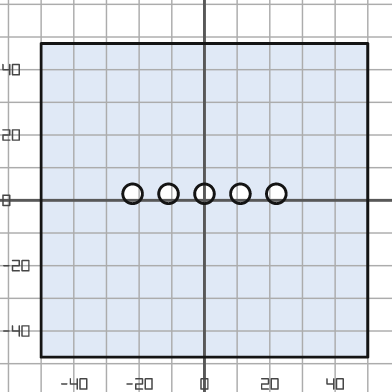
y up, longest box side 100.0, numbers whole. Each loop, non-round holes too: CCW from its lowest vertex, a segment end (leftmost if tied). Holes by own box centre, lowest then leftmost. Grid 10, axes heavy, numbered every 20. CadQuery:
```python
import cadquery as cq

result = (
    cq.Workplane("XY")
    .moveTo(-50.0, -48.0)
    .lineTo(50.0, -48.0)
    .lineTo(50.0, 48.0)
    .lineTo(-50.0, 48.0)
    .close()
    .moveTo(-22.0, 2.0)
    .circle(3.0)
    .moveTo(-11.0, 2.0)
    .circle(3.0)
    .moveTo(0.0, 2.0)
    .circle(3.0)
    .moveTo(11.0, 2.0)
    .circle(3.0)
    .moveTo(22.0, 2.0)
    .circle(3.0)
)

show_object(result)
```